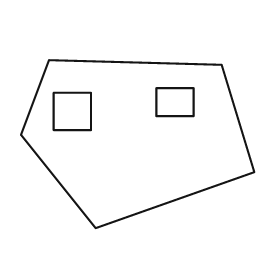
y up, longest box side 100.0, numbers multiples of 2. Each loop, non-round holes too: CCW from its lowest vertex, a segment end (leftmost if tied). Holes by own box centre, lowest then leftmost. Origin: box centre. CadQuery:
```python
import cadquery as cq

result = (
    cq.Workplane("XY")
    .moveTo(-18.0, -36.0)
    .lineTo(50.0, -12.0)
    .lineTo(36.0, 34.0)
    .lineTo(-38.0, 36.0)
    .lineTo(-50.0, 4.0)
    .close()
    .moveTo(-36.0, 6.0)
    .lineTo(-20.0, 6.0)
    .lineTo(-20.0, 22.0)
    .lineTo(-36.0, 22.0)
    .close()
    .moveTo(8.0, 12.0)
    .lineTo(24.0, 12.0)
    .lineTo(24.0, 24.0)
    .lineTo(8.0, 24.0)
    .close()
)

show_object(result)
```